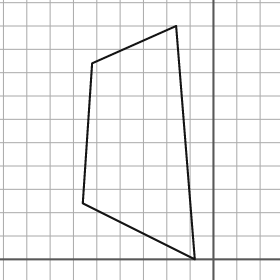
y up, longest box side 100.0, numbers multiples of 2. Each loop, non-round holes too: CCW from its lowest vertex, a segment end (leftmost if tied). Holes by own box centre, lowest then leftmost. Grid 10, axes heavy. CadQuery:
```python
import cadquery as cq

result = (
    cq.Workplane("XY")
    .moveTo(-8.0, 0.0)
    .lineTo(-16.0, 100.0)
    .lineTo(-52.0, 84.0)
    .lineTo(-56.0, 24.0)
    .close()
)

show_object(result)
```